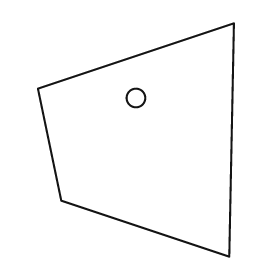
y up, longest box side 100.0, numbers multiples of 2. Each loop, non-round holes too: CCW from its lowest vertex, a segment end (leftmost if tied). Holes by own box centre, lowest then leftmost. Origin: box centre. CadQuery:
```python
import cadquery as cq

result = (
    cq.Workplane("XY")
    .moveTo(40.0, -50.0)
    .lineTo(42.0, 50.0)
    .lineTo(-42.0, 22.0)
    .lineTo(-32.0, -26.0)
    .close()
    .moveTo(0.0, 18.0)
    .circle(4.0)
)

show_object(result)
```